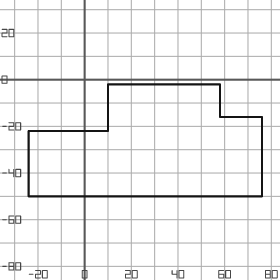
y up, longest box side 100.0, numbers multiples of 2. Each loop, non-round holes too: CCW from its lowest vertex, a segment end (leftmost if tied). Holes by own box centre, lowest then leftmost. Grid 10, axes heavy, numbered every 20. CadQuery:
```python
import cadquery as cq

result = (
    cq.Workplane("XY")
    .moveTo(-24.0, -50.0)
    .lineTo(76.0, -50.0)
    .lineTo(76.0, -16.0)
    .lineTo(58.0, -16.0)
    .lineTo(58.0, -2.0)
    .lineTo(10.0, -2.0)
    .lineTo(10.0, -22.0)
    .lineTo(-24.0, -22.0)
    .close()
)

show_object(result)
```